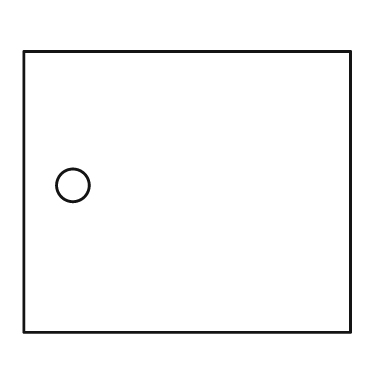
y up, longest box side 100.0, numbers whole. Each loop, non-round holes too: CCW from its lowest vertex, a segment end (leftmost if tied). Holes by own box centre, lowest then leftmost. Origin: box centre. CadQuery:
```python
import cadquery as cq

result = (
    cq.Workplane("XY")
    .moveTo(-50.0, -43.0)
    .lineTo(50.0, -43.0)
    .lineTo(50.0, 43.0)
    .lineTo(-50.0, 43.0)
    .close()
    .moveTo(-35.0, 2.0)
    .circle(5.0)
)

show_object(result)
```